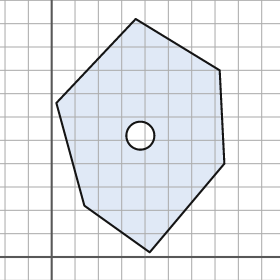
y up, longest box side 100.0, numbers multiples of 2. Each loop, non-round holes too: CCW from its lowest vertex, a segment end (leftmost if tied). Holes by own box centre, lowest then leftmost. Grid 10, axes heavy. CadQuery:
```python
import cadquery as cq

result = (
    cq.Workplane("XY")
    .moveTo(42.0, 2.0)
    .lineTo(74.0, 40.0)
    .lineTo(72.0, 80.0)
    .lineTo(36.0, 102.0)
    .lineTo(2.0, 66.0)
    .lineTo(14.0, 22.0)
    .close()
    .moveTo(38.0, 52.0)
    .circle(6.0)
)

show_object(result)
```